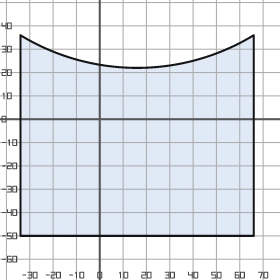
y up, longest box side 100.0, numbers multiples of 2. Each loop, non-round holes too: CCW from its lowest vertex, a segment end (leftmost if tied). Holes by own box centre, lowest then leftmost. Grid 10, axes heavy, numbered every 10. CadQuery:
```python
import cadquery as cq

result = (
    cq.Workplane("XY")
    .moveTo(-34.0, -50.0)
    .lineTo(66.0, -50.0)
    .lineTo(66.0, 36.0)
    .threePointArc((16.0, 22.0), (-34.0, 36.0))
    .close()
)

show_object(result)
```